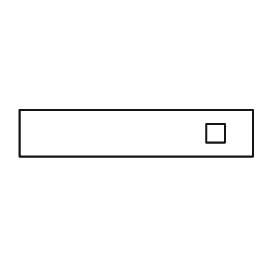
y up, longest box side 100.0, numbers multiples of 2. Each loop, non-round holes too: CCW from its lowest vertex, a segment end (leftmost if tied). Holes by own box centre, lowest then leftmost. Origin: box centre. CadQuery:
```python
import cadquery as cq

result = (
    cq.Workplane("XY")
    .moveTo(-50.0, -10.0)
    .lineTo(50.0, -10.0)
    .lineTo(50.0, 10.0)
    .lineTo(-50.0, 10.0)
    .close()
    .moveTo(30.0, -4.0)
    .lineTo(38.0, -4.0)
    .lineTo(38.0, 4.0)
    .lineTo(30.0, 4.0)
    .close()
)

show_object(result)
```